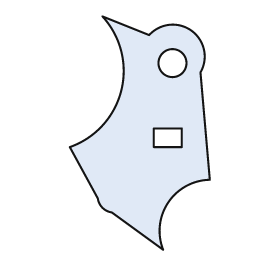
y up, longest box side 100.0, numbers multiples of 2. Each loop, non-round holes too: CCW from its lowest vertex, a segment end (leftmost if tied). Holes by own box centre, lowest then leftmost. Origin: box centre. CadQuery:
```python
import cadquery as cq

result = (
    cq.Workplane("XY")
    .moveTo(10.0, -50.0)
    .threePointArc((12.0, -30.0), (30.0, -20.0))
    .lineTo(26.0, 26.0)
    .threePointArc((22.0, 44.0), (4.0, 42.0))
    .lineTo(-16.0, 50.0)
    .threePointArc((-8.0, 18.0), (-30.0, -6.0))
    .lineTo(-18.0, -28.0)
    .threePointArc((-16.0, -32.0), (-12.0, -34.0))
    .close()
    .moveTo(6.0, -6.0)
    .lineTo(18.0, -6.0)
    .lineTo(18.0, 2.0)
    .lineTo(6.0, 2.0)
    .close()
    .moveTo(14.0, 30.0)
    .circle(6.0)
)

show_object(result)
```